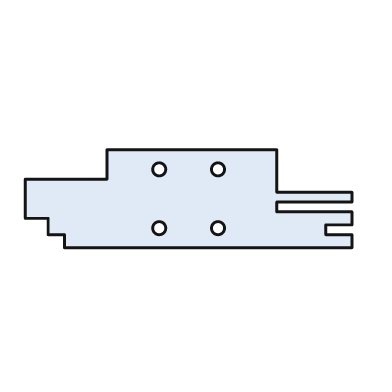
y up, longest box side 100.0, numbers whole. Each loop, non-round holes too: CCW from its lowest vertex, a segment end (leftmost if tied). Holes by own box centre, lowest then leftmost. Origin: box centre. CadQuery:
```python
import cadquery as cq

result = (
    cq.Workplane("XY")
    .moveTo(-38.0, -15.0)
    .lineTo(50.0, -15.0)
    .lineTo(50.0, -11.0)
    .lineTo(42.0, -11.0)
    .lineTo(42.0, -8.0)
    .lineTo(50.0, -8.0)
    .lineTo(50.0, -4.0)
    .lineTo(27.0, -4.0)
    .lineTo(27.0, -1.0)
    .lineTo(50.0, -1.0)
    .lineTo(50.0, 2.0)
    .lineTo(27.0, 2.0)
    .lineTo(27.0, 15.0)
    .lineTo(-25.0, 15.0)
    .lineTo(-25.0, 6.0)
    .lineTo(-50.0, 6.0)
    .lineTo(-50.0, -6.0)
    .lineTo(-43.0, -6.0)
    .lineTo(-43.0, -11.0)
    .lineTo(-38.0, -11.0)
    .close()
    .moveTo(-9.0, -9.0)
    .circle(2.0)
    .moveTo(9.0, -9.0)
    .circle(2.0)
    .moveTo(-9.0, 9.0)
    .circle(2.0)
    .moveTo(9.0, 9.0)
    .circle(2.0)
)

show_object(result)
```